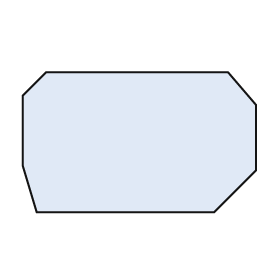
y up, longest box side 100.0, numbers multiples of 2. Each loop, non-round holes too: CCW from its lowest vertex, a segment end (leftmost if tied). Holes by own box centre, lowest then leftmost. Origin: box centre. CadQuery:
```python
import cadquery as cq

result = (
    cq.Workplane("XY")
    .moveTo(-44.0, -30.0)
    .lineTo(32.0, -30.0)
    .lineTo(50.0, -12.0)
    .lineTo(50.0, 16.0)
    .lineTo(38.0, 30.0)
    .lineTo(-40.0, 30.0)
    .lineTo(-50.0, 20.0)
    .lineTo(-50.0, -10.0)
    .close()
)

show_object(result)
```